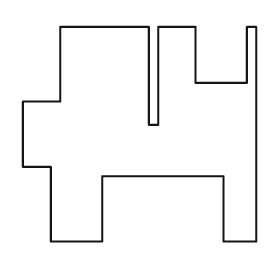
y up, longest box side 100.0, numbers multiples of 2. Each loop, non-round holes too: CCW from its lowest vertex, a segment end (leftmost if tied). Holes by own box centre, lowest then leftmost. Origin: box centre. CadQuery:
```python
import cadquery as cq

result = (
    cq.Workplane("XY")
    .moveTo(-38.0, -46.0)
    .lineTo(-16.0, -46.0)
    .lineTo(-16.0, -18.0)
    .lineTo(36.0, -18.0)
    .lineTo(36.0, -46.0)
    .lineTo(50.0, -46.0)
    .lineTo(50.0, 46.0)
    .lineTo(46.0, 46.0)
    .lineTo(46.0, 22.0)
    .lineTo(24.0, 22.0)
    .lineTo(24.0, 46.0)
    .lineTo(8.0, 46.0)
    .lineTo(8.0, 4.0)
    .lineTo(4.0, 4.0)
    .lineTo(4.0, 46.0)
    .lineTo(-34.0, 46.0)
    .lineTo(-34.0, 14.0)
    .lineTo(-50.0, 14.0)
    .lineTo(-50.0, -14.0)
    .lineTo(-38.0, -14.0)
    .close()
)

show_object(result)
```